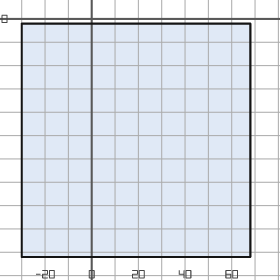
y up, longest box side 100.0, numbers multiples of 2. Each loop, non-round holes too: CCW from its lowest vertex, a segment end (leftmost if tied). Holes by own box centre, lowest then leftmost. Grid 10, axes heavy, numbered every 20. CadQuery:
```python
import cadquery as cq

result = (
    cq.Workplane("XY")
    .moveTo(-30.0, -102.0)
    .lineTo(68.0, -102.0)
    .lineTo(68.0, -2.0)
    .lineTo(-30.0, -2.0)
    .close()
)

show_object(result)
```